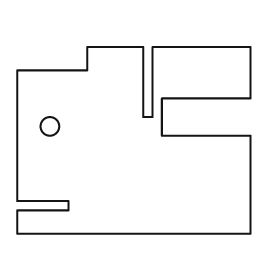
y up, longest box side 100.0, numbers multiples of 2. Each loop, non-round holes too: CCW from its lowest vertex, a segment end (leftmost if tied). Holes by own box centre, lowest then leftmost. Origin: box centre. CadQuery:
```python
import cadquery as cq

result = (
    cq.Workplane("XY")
    .moveTo(-50.0, -40.0)
    .lineTo(50.0, -40.0)
    .lineTo(50.0, 2.0)
    .lineTo(12.0, 2.0)
    .lineTo(12.0, 18.0)
    .lineTo(50.0, 18.0)
    .lineTo(50.0, 40.0)
    .lineTo(8.0, 40.0)
    .lineTo(8.0, 10.0)
    .lineTo(4.0, 10.0)
    .lineTo(4.0, 40.0)
    .lineTo(-20.0, 40.0)
    .lineTo(-20.0, 30.0)
    .lineTo(-50.0, 30.0)
    .lineTo(-50.0, -26.0)
    .lineTo(-28.0, -26.0)
    .lineTo(-28.0, -30.0)
    .lineTo(-50.0, -30.0)
    .close()
    .moveTo(-36.0, 6.0)
    .circle(4.0)
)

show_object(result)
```